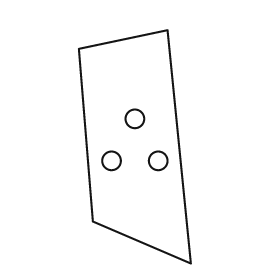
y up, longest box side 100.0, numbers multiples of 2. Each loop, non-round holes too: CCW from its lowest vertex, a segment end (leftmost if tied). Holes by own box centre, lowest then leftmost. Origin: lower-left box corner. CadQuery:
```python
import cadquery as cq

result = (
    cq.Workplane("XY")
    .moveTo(48.0, 0.0)
    .lineTo(38.0, 100.0)
    .lineTo(0.0, 92.0)
    .lineTo(6.0, 18.0)
    .close()
    .moveTo(14.0, 44.0)
    .circle(4.0)
    .moveTo(34.0, 44.0)
    .circle(4.0)
    .moveTo(24.0, 62.0)
    .circle(4.0)
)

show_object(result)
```